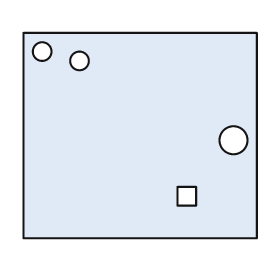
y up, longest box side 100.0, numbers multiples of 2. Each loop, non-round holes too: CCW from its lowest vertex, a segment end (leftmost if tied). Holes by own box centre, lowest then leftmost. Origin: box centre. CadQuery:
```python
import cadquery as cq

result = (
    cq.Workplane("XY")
    .moveTo(-50.0, -44.0)
    .lineTo(50.0, -44.0)
    .lineTo(50.0, 44.0)
    .lineTo(-50.0, 44.0)
    .close()
    .moveTo(16.0, -30.0)
    .lineTo(24.0, -30.0)
    .lineTo(24.0, -22.0)
    .lineTo(16.0, -22.0)
    .close()
    .moveTo(40.0, -2.0)
    .circle(6.0)
    .moveTo(-26.0, 32.0)
    .circle(4.0)
    .moveTo(-42.0, 36.0)
    .circle(4.0)
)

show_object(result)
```